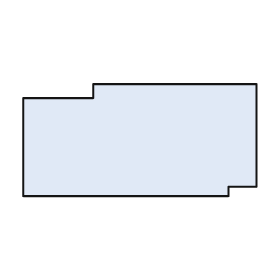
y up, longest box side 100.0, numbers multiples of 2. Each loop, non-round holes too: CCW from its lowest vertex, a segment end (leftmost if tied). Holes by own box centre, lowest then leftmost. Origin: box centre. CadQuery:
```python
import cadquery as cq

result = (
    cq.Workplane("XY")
    .moveTo(-50.0, -24.0)
    .lineTo(38.0, -24.0)
    .lineTo(38.0, -20.0)
    .lineTo(50.0, -20.0)
    .lineTo(50.0, 24.0)
    .lineTo(-20.0, 24.0)
    .lineTo(-20.0, 18.0)
    .lineTo(-50.0, 18.0)
    .close()
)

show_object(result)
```